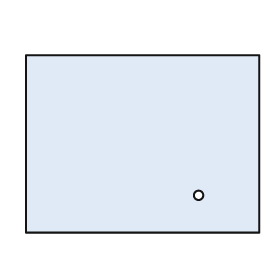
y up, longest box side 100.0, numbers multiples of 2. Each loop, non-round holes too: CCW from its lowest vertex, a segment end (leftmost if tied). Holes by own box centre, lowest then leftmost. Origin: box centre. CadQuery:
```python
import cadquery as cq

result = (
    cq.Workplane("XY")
    .moveTo(-50.0, -38.0)
    .lineTo(50.0, -38.0)
    .lineTo(50.0, 38.0)
    .lineTo(-50.0, 38.0)
    .close()
    .moveTo(24.0, -22.0)
    .circle(2.0)
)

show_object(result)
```